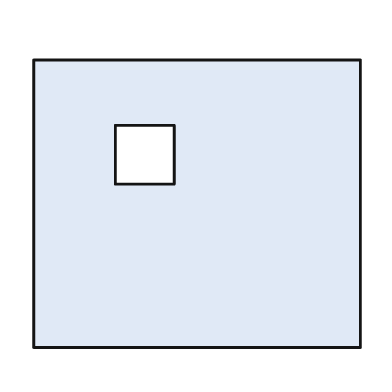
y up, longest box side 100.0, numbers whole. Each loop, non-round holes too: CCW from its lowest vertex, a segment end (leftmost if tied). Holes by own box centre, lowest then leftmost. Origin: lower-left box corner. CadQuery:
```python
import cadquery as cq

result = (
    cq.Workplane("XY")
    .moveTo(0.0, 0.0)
    .lineTo(100.0, 0.0)
    .lineTo(100.0, 88.0)
    .lineTo(0.0, 88.0)
    .close()
    .moveTo(25.0, 50.0)
    .lineTo(43.0, 50.0)
    .lineTo(43.0, 68.0)
    .lineTo(25.0, 68.0)
    .close()
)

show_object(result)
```